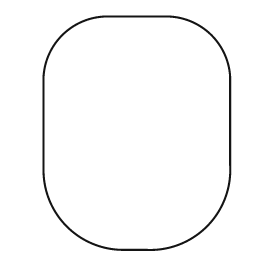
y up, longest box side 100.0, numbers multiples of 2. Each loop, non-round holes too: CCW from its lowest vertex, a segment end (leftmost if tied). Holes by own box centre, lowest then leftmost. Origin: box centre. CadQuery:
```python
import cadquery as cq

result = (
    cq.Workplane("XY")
    .moveTo(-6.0, -50.0)
    .lineTo(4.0, -50.0)
    .threePointArc((30.0, -40.0), (40.0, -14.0))
    .lineTo(40.0, 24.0)
    .threePointArc((32.0, 42.0), (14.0, 50.0))
    .lineTo(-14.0, 50.0)
    .threePointArc((-32.0, 42.0), (-40.0, 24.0))
    .lineTo(-40.0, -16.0)
    .threePointArc((-30.0, -40.0), (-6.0, -50.0))
    .close()
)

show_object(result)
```